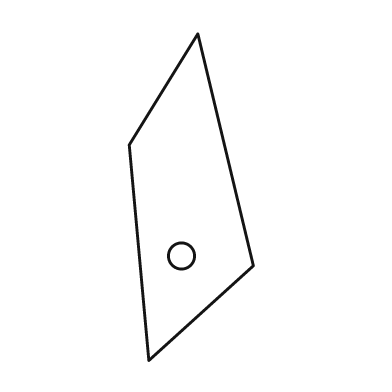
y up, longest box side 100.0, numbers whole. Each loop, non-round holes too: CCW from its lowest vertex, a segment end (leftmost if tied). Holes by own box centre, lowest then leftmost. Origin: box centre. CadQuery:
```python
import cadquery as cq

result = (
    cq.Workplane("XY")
    .moveTo(-13.0, -50.0)
    .lineTo(19.0, -21.0)
    .lineTo(2.0, 50.0)
    .lineTo(-19.0, 16.0)
    .close()
    .moveTo(-3.0, -18.0)
    .circle(4.0)
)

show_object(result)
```